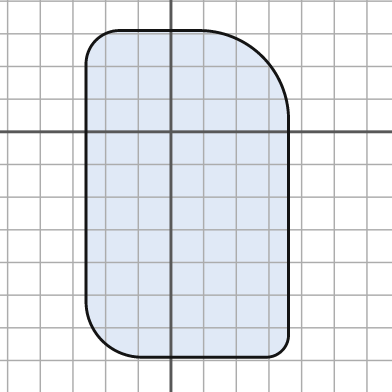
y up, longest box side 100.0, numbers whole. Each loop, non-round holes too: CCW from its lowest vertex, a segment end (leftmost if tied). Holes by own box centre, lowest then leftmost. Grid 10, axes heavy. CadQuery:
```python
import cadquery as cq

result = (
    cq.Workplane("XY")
    .moveTo(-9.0, -69.0)
    .lineTo(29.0, -69.0)
    .threePointArc((34.0, -67.0), (36.0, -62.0))
    .lineTo(36.0, 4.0)
    .threePointArc((28.0, 23.0), (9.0, 31.0))
    .lineTo(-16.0, 31.0)
    .threePointArc((-23.0, 28.0), (-26.0, 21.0))
    .lineTo(-26.0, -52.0)
    .threePointArc((-21.0, -64.0), (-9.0, -69.0))
    .close()
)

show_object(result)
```